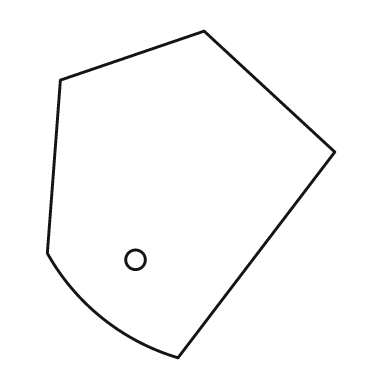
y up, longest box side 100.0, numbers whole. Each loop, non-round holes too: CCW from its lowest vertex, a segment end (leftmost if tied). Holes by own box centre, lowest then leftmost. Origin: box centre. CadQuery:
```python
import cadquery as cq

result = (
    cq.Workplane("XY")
    .moveTo(-4.0, -50.0)
    .lineTo(44.0, 13.0)
    .lineTo(4.0, 50.0)
    .lineTo(-40.0, 35.0)
    .lineTo(-44.0, -18.0)
    .threePointArc((-27.0, -38.0), (-4.0, -50.0))
    .close()
    .moveTo(-17.0, -20.0)
    .circle(3.0)
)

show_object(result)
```